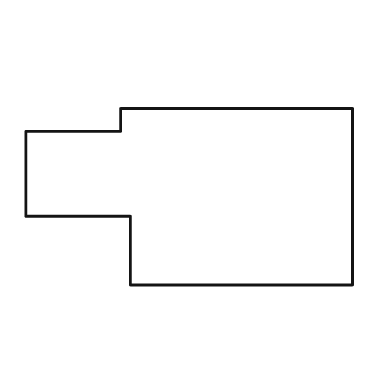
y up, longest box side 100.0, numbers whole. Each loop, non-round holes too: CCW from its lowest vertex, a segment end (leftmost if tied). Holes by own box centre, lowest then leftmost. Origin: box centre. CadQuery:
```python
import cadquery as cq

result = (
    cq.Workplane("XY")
    .moveTo(-18.0, -27.0)
    .lineTo(50.0, -27.0)
    .lineTo(50.0, 27.0)
    .lineTo(-21.0, 27.0)
    .lineTo(-21.0, 20.0)
    .lineTo(-50.0, 20.0)
    .lineTo(-50.0, -6.0)
    .lineTo(-18.0, -6.0)
    .close()
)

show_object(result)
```